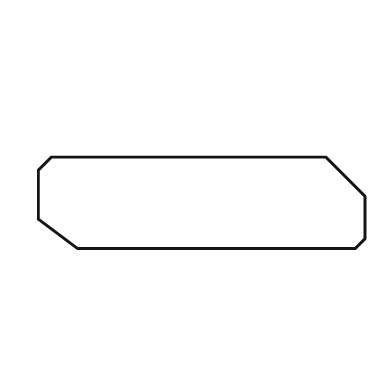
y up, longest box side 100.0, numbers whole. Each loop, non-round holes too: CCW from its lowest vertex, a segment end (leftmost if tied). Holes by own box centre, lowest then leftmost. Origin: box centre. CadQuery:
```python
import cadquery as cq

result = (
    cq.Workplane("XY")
    .moveTo(-38.0, -14.0)
    .lineTo(47.0, -14.0)
    .lineTo(50.0, -11.0)
    .lineTo(50.0, 2.0)
    .lineTo(38.0, 14.0)
    .lineTo(-46.0, 14.0)
    .lineTo(-50.0, 10.0)
    .lineTo(-50.0, -5.0)
    .close()
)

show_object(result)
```